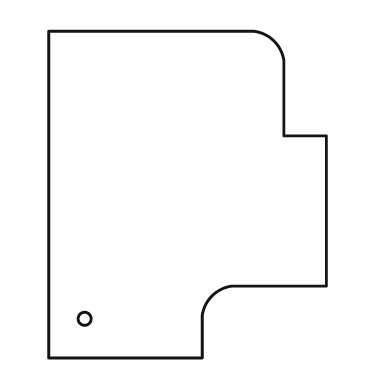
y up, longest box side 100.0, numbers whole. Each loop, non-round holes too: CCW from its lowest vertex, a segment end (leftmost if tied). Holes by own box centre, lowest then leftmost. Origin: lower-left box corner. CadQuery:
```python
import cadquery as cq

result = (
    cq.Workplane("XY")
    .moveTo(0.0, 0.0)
    .lineTo(47.0, 0.0)
    .lineTo(47.0, 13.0)
    .threePointArc((50.0, 19.0), (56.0, 22.0))
    .lineTo(85.0, 22.0)
    .lineTo(85.0, 68.0)
    .lineTo(72.0, 68.0)
    .lineTo(72.0, 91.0)
    .threePointArc((69.0, 97.0), (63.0, 100.0))
    .lineTo(0.0, 100.0)
    .close()
    .moveTo(11.0, 12.0)
    .circle(2.0)
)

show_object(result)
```